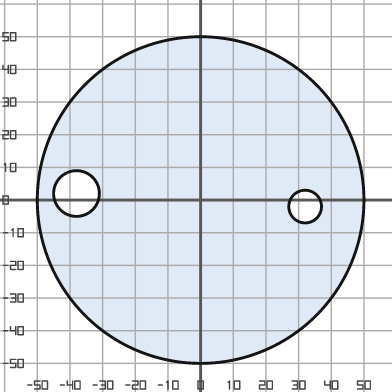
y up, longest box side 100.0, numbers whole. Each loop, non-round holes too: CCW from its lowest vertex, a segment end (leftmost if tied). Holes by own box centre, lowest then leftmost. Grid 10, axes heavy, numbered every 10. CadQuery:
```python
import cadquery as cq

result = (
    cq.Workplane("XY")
    .moveTo(0.0, 0.0)
    .circle(50.0)
    .moveTo(32.0, -2.0)
    .circle(5.0)
    .moveTo(-38.0, 2.0)
    .circle(7.0)
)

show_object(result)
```